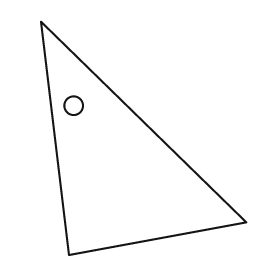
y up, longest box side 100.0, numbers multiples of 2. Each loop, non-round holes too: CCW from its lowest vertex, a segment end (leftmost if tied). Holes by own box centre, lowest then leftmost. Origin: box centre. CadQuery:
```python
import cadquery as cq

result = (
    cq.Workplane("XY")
    .moveTo(-32.0, -50.0)
    .lineTo(44.0, -36.0)
    .lineTo(-44.0, 50.0)
    .close()
    .moveTo(-30.0, 14.0)
    .circle(4.0)
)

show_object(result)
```